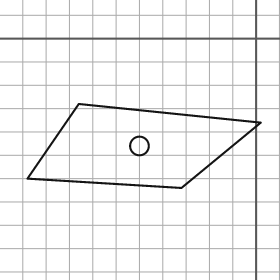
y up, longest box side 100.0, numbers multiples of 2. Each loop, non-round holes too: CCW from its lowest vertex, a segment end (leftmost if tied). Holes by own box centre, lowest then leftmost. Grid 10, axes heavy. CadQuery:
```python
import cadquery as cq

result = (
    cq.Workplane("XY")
    .moveTo(-32.0, -64.0)
    .lineTo(2.0, -36.0)
    .lineTo(-76.0, -28.0)
    .lineTo(-98.0, -60.0)
    .close()
    .moveTo(-50.0, -46.0)
    .circle(4.0)
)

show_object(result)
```